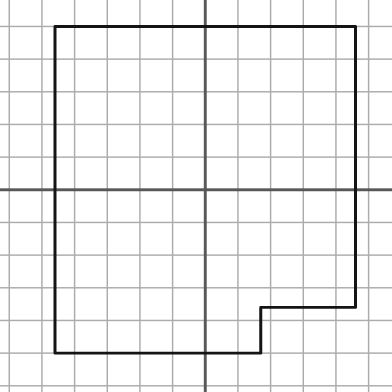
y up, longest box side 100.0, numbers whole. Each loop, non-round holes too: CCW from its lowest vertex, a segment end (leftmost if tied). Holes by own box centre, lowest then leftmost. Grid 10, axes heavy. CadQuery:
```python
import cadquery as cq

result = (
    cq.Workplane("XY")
    .moveTo(-46.0, -50.0)
    .lineTo(17.0, -50.0)
    .lineTo(17.0, -36.0)
    .lineTo(46.0, -36.0)
    .lineTo(46.0, 50.0)
    .lineTo(-46.0, 50.0)
    .close()
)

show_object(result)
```